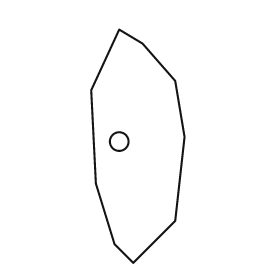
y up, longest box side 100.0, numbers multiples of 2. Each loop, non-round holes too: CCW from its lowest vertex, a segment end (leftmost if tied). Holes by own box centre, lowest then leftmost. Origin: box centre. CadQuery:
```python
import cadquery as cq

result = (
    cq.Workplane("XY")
    .moveTo(-2.0, -50.0)
    .lineTo(16.0, -32.0)
    .lineTo(20.0, 4.0)
    .lineTo(16.0, 28.0)
    .lineTo(2.0, 44.0)
    .lineTo(-8.0, 50.0)
    .lineTo(-20.0, 24.0)
    .lineTo(-18.0, -16.0)
    .lineTo(-10.0, -42.0)
    .close()
    .moveTo(-8.0, 2.0)
    .circle(4.0)
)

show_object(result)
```